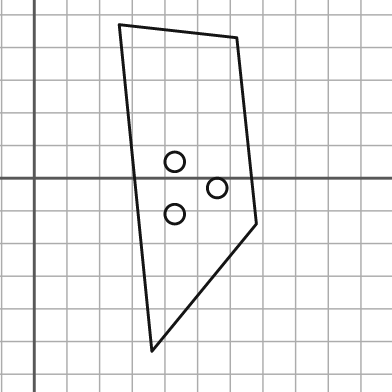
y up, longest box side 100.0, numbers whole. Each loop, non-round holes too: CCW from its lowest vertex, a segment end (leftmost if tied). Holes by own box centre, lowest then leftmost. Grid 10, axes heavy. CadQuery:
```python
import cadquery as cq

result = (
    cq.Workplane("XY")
    .moveTo(36.0, -53.0)
    .lineTo(68.0, -14.0)
    .lineTo(62.0, 43.0)
    .lineTo(26.0, 47.0)
    .close()
    .moveTo(43.0, -11.0)
    .circle(3.0)
    .moveTo(56.0, -3.0)
    .circle(3.0)
    .moveTo(43.0, 5.0)
    .circle(3.0)
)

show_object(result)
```